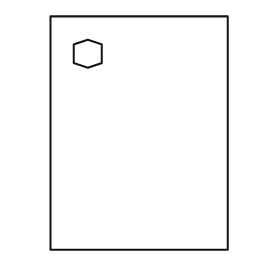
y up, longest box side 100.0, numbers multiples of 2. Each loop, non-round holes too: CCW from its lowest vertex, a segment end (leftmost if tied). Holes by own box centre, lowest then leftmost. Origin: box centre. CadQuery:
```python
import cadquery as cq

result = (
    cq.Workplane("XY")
    .moveTo(-38.0, -50.0)
    .lineTo(38.0, -50.0)
    .lineTo(38.0, 50.0)
    .lineTo(-38.0, 50.0)
    .close()
    .moveTo(-22.0, 28.0)
    .lineTo(-16.0, 30.0)
    .lineTo(-16.0, 38.0)
    .lineTo(-22.0, 40.0)
    .lineTo(-28.0, 38.0)
    .lineTo(-28.0, 30.0)
    .close()
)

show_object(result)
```